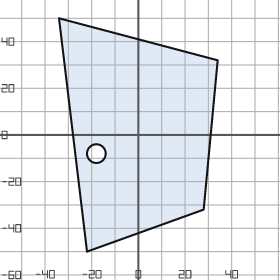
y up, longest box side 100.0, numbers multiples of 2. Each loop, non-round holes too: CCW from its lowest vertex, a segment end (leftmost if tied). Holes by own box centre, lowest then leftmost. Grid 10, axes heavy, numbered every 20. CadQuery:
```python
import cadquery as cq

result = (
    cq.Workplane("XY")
    .moveTo(-22.0, -50.0)
    .lineTo(28.0, -32.0)
    .lineTo(34.0, 32.0)
    .lineTo(-34.0, 50.0)
    .close()
    .moveTo(-18.0, -8.0)
    .circle(4.0)
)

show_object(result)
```